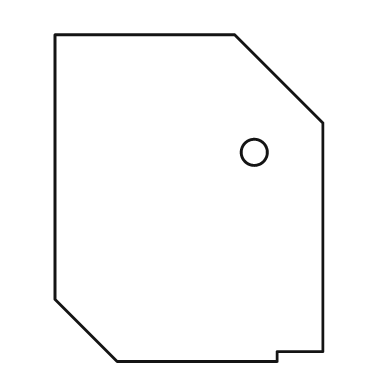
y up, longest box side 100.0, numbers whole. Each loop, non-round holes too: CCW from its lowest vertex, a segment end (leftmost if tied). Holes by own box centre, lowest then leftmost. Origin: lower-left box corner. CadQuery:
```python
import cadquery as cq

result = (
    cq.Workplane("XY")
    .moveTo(19.0, 0.0)
    .lineTo(68.0, 0.0)
    .lineTo(68.0, 3.0)
    .lineTo(82.0, 3.0)
    .lineTo(82.0, 73.0)
    .lineTo(55.0, 100.0)
    .lineTo(0.0, 100.0)
    .lineTo(0.0, 19.0)
    .close()
    .moveTo(61.0, 64.0)
    .circle(4.0)
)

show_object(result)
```